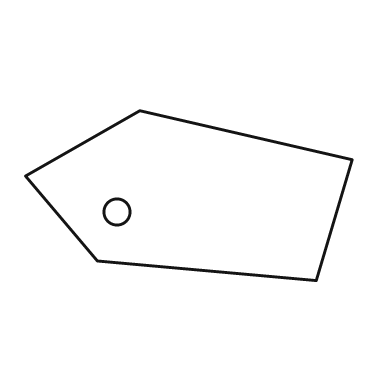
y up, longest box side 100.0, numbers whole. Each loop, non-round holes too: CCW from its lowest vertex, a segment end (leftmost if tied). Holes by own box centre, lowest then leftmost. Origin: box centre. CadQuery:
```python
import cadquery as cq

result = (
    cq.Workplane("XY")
    .moveTo(39.0, -26.0)
    .lineTo(50.0, 11.0)
    .lineTo(-15.0, 26.0)
    .lineTo(-50.0, 6.0)
    .lineTo(-28.0, -20.0)
    .close()
    .moveTo(-22.0, -5.0)
    .circle(4.0)
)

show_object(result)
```